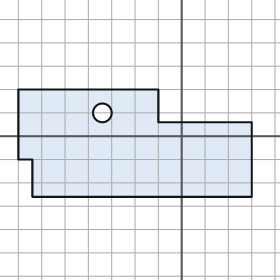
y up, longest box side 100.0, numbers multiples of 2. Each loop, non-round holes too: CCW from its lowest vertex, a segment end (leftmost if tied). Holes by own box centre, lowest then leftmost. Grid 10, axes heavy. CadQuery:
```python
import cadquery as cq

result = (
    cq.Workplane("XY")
    .moveTo(-64.0, -26.0)
    .lineTo(30.0, -26.0)
    .lineTo(30.0, 6.0)
    .lineTo(-10.0, 6.0)
    .lineTo(-10.0, 20.0)
    .lineTo(-70.0, 20.0)
    .lineTo(-70.0, -10.0)
    .lineTo(-64.0, -10.0)
    .close()
    .moveTo(-34.0, 10.0)
    .circle(4.0)
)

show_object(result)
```